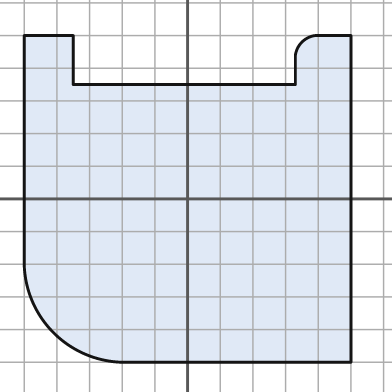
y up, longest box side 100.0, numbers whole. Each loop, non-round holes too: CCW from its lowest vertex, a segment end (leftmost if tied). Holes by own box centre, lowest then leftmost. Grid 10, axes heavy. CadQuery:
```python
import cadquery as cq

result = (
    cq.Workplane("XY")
    .moveTo(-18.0, -50.0)
    .lineTo(50.0, -50.0)
    .lineTo(50.0, 50.0)
    .lineTo(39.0, 50.0)
    .threePointArc((35.0, 48.0), (33.0, 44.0))
    .lineTo(33.0, 35.0)
    .lineTo(-35.0, 35.0)
    .lineTo(-35.0, 50.0)
    .lineTo(-50.0, 50.0)
    .lineTo(-50.0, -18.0)
    .threePointArc((-41.0, -41.0), (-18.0, -50.0))
    .close()
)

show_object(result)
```